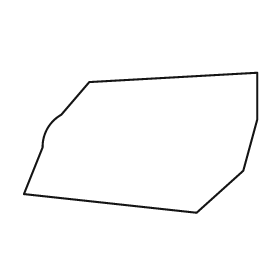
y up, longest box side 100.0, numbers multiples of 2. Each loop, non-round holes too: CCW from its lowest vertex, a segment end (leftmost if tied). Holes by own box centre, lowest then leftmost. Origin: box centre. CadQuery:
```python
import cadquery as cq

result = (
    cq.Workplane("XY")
    .moveTo(24.0, -30.0)
    .lineTo(44.0, -12.0)
    .lineTo(50.0, 10.0)
    .lineTo(50.0, 30.0)
    .lineTo(-22.0, 26.0)
    .lineTo(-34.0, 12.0)
    .threePointArc((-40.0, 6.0), (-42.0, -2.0))
    .lineTo(-50.0, -22.0)
    .close()
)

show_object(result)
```